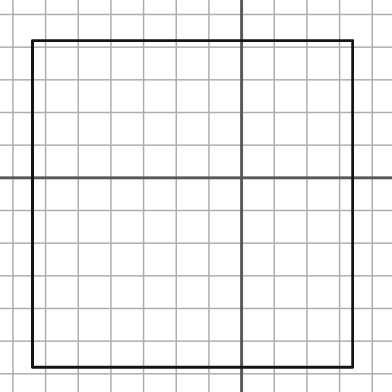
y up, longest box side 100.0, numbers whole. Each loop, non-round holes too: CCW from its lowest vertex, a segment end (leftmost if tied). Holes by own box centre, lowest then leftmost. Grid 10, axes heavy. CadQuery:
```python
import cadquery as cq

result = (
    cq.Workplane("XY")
    .moveTo(-64.0, -58.0)
    .lineTo(34.0, -58.0)
    .lineTo(34.0, 42.0)
    .lineTo(-64.0, 42.0)
    .close()
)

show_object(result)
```